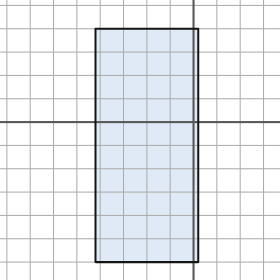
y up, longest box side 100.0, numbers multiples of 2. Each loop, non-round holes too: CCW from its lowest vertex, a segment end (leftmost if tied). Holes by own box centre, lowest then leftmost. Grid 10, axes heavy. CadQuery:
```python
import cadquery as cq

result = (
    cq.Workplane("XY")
    .moveTo(-42.0, -60.0)
    .lineTo(2.0, -60.0)
    .lineTo(2.0, 40.0)
    .lineTo(-42.0, 40.0)
    .close()
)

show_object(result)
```